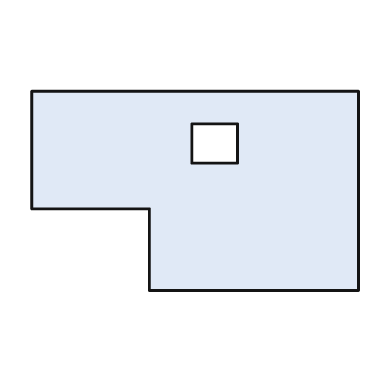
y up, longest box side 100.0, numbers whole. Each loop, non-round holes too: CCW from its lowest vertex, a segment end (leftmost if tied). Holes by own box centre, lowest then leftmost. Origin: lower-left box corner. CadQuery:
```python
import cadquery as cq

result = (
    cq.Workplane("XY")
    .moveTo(36.0, 0.0)
    .lineTo(100.0, 0.0)
    .lineTo(100.0, 61.0)
    .lineTo(0.0, 61.0)
    .lineTo(0.0, 25.0)
    .lineTo(36.0, 25.0)
    .close()
    .moveTo(49.0, 39.0)
    .lineTo(63.0, 39.0)
    .lineTo(63.0, 51.0)
    .lineTo(49.0, 51.0)
    .close()
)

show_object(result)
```